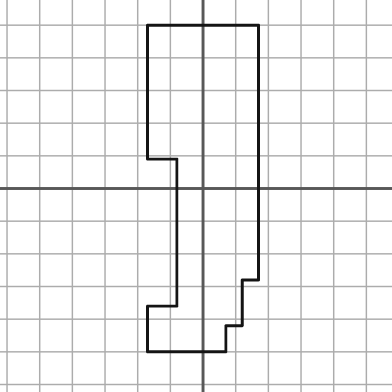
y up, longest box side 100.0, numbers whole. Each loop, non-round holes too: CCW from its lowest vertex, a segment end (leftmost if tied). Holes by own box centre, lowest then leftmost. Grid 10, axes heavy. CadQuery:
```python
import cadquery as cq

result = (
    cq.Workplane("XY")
    .moveTo(-17.0, -50.0)
    .lineTo(7.0, -50.0)
    .lineTo(7.0, -42.0)
    .lineTo(12.0, -42.0)
    .lineTo(12.0, -28.0)
    .lineTo(17.0, -28.0)
    .lineTo(17.0, 50.0)
    .lineTo(-17.0, 50.0)
    .lineTo(-17.0, 9.0)
    .lineTo(-8.0, 9.0)
    .lineTo(-8.0, -36.0)
    .lineTo(-17.0, -36.0)
    .close()
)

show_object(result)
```